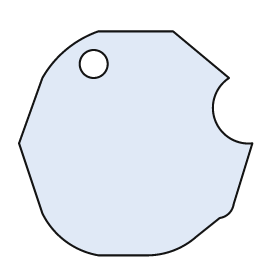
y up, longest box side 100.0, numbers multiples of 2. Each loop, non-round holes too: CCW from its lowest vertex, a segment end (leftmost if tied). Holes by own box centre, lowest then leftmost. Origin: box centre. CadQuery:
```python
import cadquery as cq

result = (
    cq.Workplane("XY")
    .moveTo(-16.0, -48.0)
    .lineTo(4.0, -48.0)
    .threePointArc((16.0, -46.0), (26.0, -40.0))
    .lineTo(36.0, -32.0)
    .threePointArc((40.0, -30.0), (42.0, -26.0))
    .lineTo(50.0, 0.0)
    .threePointArc((34.0, 10.0), (40.0, 28.0))
    .lineTo(16.0, 48.0)
    .lineTo(-16.0, 48.0)
    .threePointArc((-30.0, 40.0), (-40.0, 28.0))
    .lineTo(-50.0, 0.0)
    .lineTo(-40.0, -30.0)
    .threePointArc((-30.0, -42.0), (-16.0, -48.0))
    .close()
    .moveTo(-18.0, 34.0)
    .circle(6.0)
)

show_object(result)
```